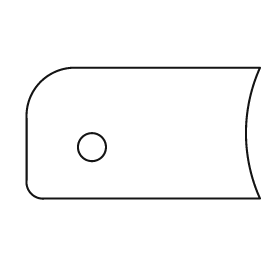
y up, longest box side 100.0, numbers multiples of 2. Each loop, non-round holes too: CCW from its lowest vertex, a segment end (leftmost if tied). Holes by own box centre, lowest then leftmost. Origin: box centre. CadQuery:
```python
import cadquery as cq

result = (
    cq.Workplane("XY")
    .moveTo(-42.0, -28.0)
    .lineTo(50.0, -28.0)
    .threePointArc((44.0, 0.0), (50.0, 28.0))
    .lineTo(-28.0, 28.0)
    .threePointArc((-44.0, 22.0), (-50.0, 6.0))
    .lineTo(-50.0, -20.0)
    .threePointArc((-48.0, -26.0), (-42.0, -28.0))
    .close()
    .moveTo(-22.0, -6.0)
    .circle(6.0)
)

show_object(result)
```